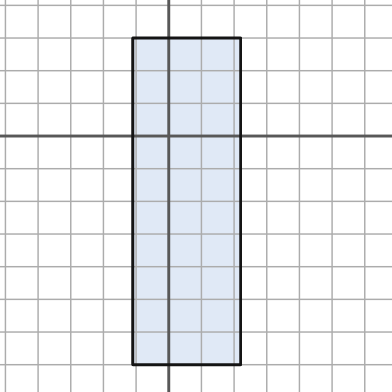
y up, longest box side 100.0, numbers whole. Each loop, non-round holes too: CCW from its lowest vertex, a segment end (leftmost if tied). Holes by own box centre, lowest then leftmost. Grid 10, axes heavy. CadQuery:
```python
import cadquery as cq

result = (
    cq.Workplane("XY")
    .moveTo(-11.0, -70.0)
    .lineTo(22.0, -70.0)
    .lineTo(22.0, 30.0)
    .lineTo(-11.0, 30.0)
    .close()
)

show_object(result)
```